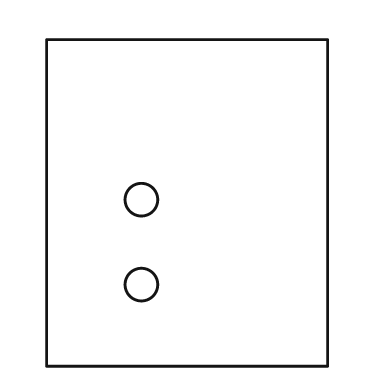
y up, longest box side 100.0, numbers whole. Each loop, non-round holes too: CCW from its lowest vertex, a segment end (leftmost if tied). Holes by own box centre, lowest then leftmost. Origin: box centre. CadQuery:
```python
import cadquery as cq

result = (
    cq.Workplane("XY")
    .moveTo(-43.0, -50.0)
    .lineTo(43.0, -50.0)
    .lineTo(43.0, 50.0)
    .lineTo(-43.0, 50.0)
    .close()
    .moveTo(-14.0, -25.0)
    .circle(5.0)
    .moveTo(-14.0, 1.0)
    .circle(5.0)
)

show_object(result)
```